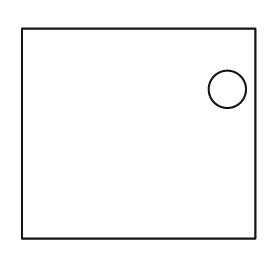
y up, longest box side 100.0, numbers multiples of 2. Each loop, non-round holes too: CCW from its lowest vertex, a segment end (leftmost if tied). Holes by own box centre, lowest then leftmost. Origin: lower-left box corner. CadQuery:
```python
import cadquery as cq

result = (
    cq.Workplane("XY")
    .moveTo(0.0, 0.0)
    .lineTo(100.0, 0.0)
    .lineTo(100.0, 90.0)
    .lineTo(0.0, 90.0)
    .close()
    .moveTo(88.0, 64.0)
    .circle(8.0)
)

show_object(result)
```